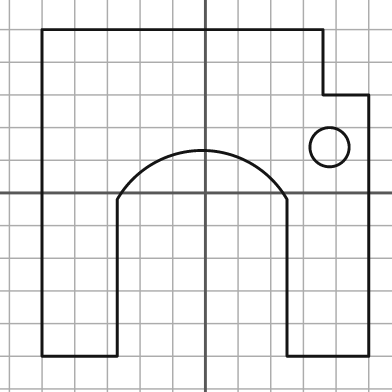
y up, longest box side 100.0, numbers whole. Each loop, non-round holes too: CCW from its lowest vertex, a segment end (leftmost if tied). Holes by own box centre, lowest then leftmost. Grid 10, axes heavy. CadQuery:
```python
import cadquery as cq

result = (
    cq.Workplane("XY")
    .moveTo(-50.0, -50.0)
    .lineTo(-27.0, -50.0)
    .lineTo(-27.0, -2.0)
    .threePointArc((-1.0, 13.0), (25.0, -2.0))
    .lineTo(25.0, -50.0)
    .lineTo(50.0, -50.0)
    .lineTo(50.0, 30.0)
    .lineTo(36.0, 30.0)
    .lineTo(36.0, 50.0)
    .lineTo(-50.0, 50.0)
    .close()
    .moveTo(38.0, 14.0)
    .circle(6.0)
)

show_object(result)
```